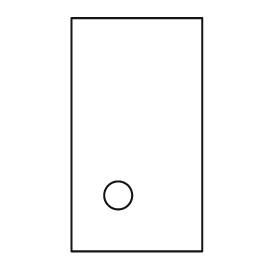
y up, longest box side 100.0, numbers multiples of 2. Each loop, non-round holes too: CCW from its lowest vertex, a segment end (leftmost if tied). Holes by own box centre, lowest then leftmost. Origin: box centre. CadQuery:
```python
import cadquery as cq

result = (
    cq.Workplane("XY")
    .moveTo(-28.0, -50.0)
    .lineTo(28.0, -50.0)
    .lineTo(28.0, 50.0)
    .lineTo(-28.0, 50.0)
    .close()
    .moveTo(-8.0, -26.0)
    .circle(6.0)
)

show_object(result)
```